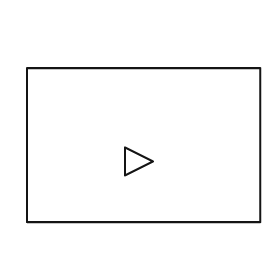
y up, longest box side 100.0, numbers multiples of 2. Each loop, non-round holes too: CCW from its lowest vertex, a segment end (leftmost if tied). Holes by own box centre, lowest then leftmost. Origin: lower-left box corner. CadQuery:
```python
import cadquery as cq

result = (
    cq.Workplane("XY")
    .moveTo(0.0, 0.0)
    .lineTo(100.0, 0.0)
    .lineTo(100.0, 66.0)
    .lineTo(0.0, 66.0)
    .close()
    .moveTo(42.0, 20.0)
    .lineTo(54.0, 26.0)
    .lineTo(42.0, 32.0)
    .close()
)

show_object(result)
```